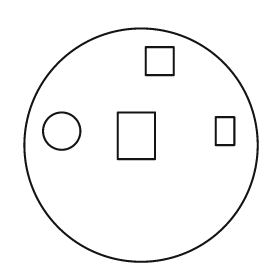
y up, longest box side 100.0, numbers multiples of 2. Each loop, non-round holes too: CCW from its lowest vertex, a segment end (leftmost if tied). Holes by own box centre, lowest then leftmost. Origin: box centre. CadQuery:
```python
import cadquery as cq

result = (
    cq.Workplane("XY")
    .moveTo(0.0, 0.0)
    .circle(50.0)
    .moveTo(-10.0, -6.0)
    .lineTo(6.0, -6.0)
    .lineTo(6.0, 14.0)
    .lineTo(-10.0, 14.0)
    .close()
    .moveTo(-34.0, 6.0)
    .circle(8.0)
    .moveTo(32.0, 0.0)
    .lineTo(40.0, 0.0)
    .lineTo(40.0, 12.0)
    .lineTo(32.0, 12.0)
    .close()
    .moveTo(2.0, 30.0)
    .lineTo(14.0, 30.0)
    .lineTo(14.0, 42.0)
    .lineTo(2.0, 42.0)
    .close()
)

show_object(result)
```